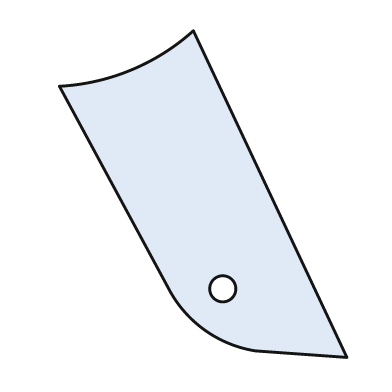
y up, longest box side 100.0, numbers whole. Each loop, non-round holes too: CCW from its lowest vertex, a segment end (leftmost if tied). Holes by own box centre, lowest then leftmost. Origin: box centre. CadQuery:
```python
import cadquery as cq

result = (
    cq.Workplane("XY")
    .moveTo(44.0, -50.0)
    .lineTo(-3.0, 50.0)
    .threePointArc((-22.0, 38.0), (-44.0, 33.0))
    .lineTo(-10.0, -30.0)
    .threePointArc((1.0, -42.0), (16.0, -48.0))
    .close()
    .moveTo(6.0, -29.0)
    .circle(4.0)
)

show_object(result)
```